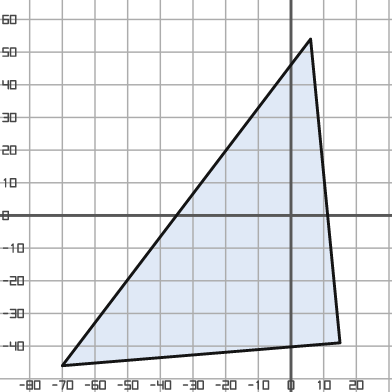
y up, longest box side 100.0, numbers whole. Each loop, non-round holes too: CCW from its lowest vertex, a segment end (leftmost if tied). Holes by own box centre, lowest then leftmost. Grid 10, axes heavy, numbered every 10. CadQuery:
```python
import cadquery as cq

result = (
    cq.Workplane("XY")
    .moveTo(-70.0, -46.0)
    .lineTo(15.0, -39.0)
    .lineTo(6.0, 54.0)
    .close()
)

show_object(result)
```